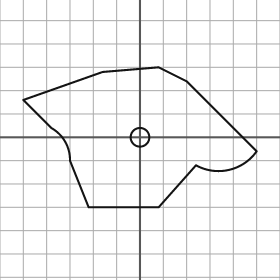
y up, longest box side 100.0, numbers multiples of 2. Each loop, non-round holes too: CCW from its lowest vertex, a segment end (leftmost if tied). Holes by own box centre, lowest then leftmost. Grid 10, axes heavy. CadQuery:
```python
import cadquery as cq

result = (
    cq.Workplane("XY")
    .moveTo(-22.0, -30.0)
    .lineTo(8.0, -30.0)
    .lineTo(24.0, -12.0)
    .threePointArc((38.0, -14.0), (50.0, -6.0))
    .lineTo(20.0, 24.0)
    .lineTo(8.0, 30.0)
    .lineTo(-16.0, 28.0)
    .lineTo(-50.0, 16.0)
    .lineTo(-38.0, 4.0)
    .threePointArc((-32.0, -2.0), (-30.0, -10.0))
    .close()
    .moveTo(0.0, 0.0)
    .circle(4.0)
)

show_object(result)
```